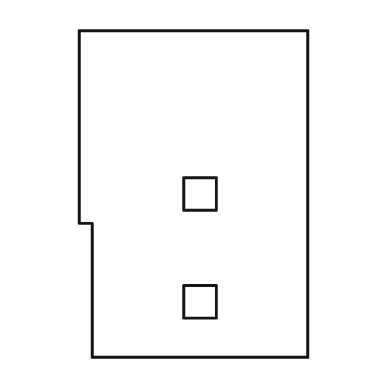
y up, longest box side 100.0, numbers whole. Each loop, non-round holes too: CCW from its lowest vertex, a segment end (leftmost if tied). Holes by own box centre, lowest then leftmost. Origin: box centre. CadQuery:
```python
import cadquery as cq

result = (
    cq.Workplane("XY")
    .moveTo(-31.0, -50.0)
    .lineTo(35.0, -50.0)
    .lineTo(35.0, 50.0)
    .lineTo(-35.0, 50.0)
    .lineTo(-35.0, -9.0)
    .lineTo(-31.0, -9.0)
    .close()
    .moveTo(-3.0, -38.0)
    .lineTo(7.0, -38.0)
    .lineTo(7.0, -28.0)
    .lineTo(-3.0, -28.0)
    .close()
    .moveTo(-3.0, -5.0)
    .lineTo(7.0, -5.0)
    .lineTo(7.0, 5.0)
    .lineTo(-3.0, 5.0)
    .close()
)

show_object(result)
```